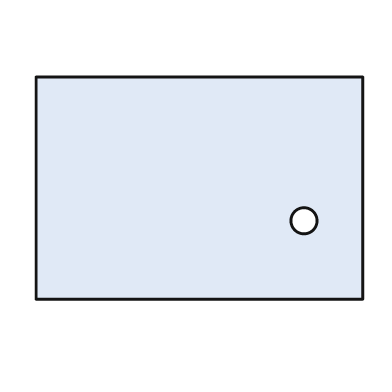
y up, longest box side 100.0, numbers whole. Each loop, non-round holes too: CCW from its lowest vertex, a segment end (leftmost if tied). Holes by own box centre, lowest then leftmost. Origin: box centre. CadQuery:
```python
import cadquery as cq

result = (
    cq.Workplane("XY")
    .moveTo(-50.0, -34.0)
    .lineTo(50.0, -34.0)
    .lineTo(50.0, 34.0)
    .lineTo(-50.0, 34.0)
    .close()
    .moveTo(32.0, -10.0)
    .circle(4.0)
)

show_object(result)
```